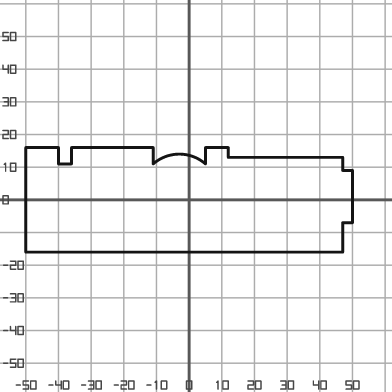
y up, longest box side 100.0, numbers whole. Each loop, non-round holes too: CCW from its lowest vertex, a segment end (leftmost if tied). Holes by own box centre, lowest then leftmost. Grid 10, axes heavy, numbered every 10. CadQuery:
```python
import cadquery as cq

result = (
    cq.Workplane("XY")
    .moveTo(-50.0, -16.0)
    .lineTo(47.0, -16.0)
    .lineTo(47.0, -7.0)
    .lineTo(50.0, -7.0)
    .lineTo(50.0, 9.0)
    .lineTo(47.0, 9.0)
    .lineTo(47.0, 13.0)
    .lineTo(12.0, 13.0)
    .lineTo(12.0, 16.0)
    .lineTo(5.0, 16.0)
    .lineTo(5.0, 11.0)
    .threePointArc((-3.0, 14.0), (-11.0, 11.0))
    .lineTo(-11.0, 16.0)
    .lineTo(-36.0, 16.0)
    .lineTo(-36.0, 11.0)
    .lineTo(-40.0, 11.0)
    .lineTo(-40.0, 16.0)
    .lineTo(-50.0, 16.0)
    .close()
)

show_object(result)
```